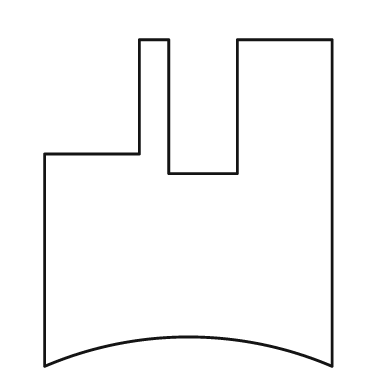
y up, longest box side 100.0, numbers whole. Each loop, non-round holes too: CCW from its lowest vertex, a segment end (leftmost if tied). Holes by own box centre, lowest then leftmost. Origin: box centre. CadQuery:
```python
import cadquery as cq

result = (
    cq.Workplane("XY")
    .moveTo(-44.0, -50.0)
    .threePointArc((0.0, -41.0), (44.0, -50.0))
    .lineTo(44.0, 50.0)
    .lineTo(15.0, 50.0)
    .lineTo(15.0, 9.0)
    .lineTo(-6.0, 9.0)
    .lineTo(-6.0, 50.0)
    .lineTo(-15.0, 50.0)
    .lineTo(-15.0, 15.0)
    .lineTo(-44.0, 15.0)
    .close()
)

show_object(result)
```